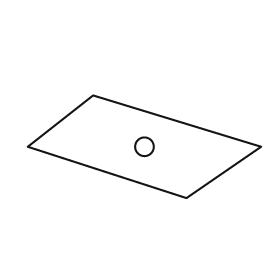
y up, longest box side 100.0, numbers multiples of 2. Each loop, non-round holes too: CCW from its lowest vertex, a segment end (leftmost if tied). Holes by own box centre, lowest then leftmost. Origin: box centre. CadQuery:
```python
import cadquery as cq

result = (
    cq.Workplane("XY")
    .moveTo(18.0, -22.0)
    .lineTo(50.0, 0.0)
    .lineTo(-22.0, 22.0)
    .lineTo(-50.0, 0.0)
    .close()
    .moveTo(0.0, 0.0)
    .circle(4.0)
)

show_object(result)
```